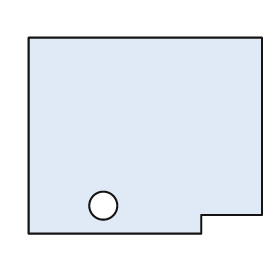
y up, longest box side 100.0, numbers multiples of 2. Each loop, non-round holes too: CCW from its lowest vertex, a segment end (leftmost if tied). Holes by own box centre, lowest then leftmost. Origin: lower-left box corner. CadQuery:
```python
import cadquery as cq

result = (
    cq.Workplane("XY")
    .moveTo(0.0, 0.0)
    .lineTo(74.0, 0.0)
    .lineTo(74.0, 8.0)
    .lineTo(100.0, 8.0)
    .lineTo(100.0, 84.0)
    .lineTo(0.0, 84.0)
    .close()
    .moveTo(32.0, 12.0)
    .circle(6.0)
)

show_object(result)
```